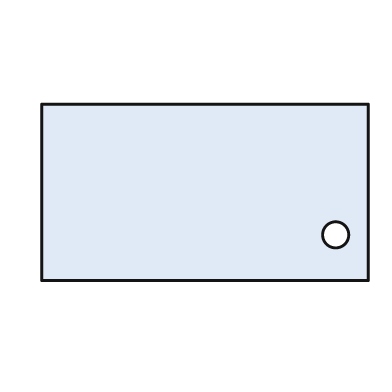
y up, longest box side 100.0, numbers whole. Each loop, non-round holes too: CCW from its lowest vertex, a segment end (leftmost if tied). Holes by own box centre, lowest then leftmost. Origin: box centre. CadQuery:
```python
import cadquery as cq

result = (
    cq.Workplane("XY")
    .moveTo(-50.0, -27.0)
    .lineTo(50.0, -27.0)
    .lineTo(50.0, 27.0)
    .lineTo(-50.0, 27.0)
    .close()
    .moveTo(40.0, -13.0)
    .circle(4.0)
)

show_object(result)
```